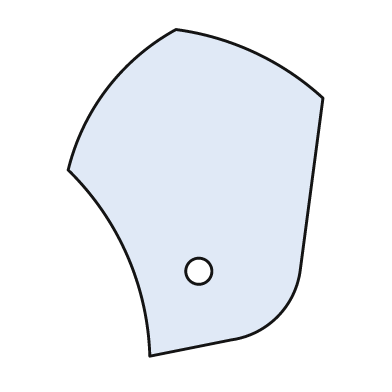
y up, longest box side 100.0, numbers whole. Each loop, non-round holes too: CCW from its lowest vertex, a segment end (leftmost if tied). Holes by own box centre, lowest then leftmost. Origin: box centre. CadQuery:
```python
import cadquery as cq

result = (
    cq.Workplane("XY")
    .moveTo(-14.0, -50.0)
    .lineTo(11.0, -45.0)
    .threePointArc((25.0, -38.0), (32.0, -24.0))
    .lineTo(39.0, 29.0)
    .threePointArc((18.0, 43.0), (-6.0, 50.0))
    .threePointArc((-27.0, 32.0), (-39.0, 7.0))
    .threePointArc((-21.0, -19.0), (-14.0, -50.0))
    .close()
    .moveTo(1.0, -24.0)
    .circle(4.0)
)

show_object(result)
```